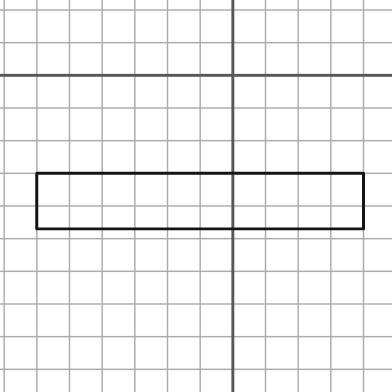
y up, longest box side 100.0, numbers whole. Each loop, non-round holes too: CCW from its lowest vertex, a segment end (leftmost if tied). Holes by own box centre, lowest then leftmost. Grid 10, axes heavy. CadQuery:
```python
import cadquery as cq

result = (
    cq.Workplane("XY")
    .moveTo(-60.0, -47.0)
    .lineTo(40.0, -47.0)
    .lineTo(40.0, -30.0)
    .lineTo(-60.0, -30.0)
    .close()
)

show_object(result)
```